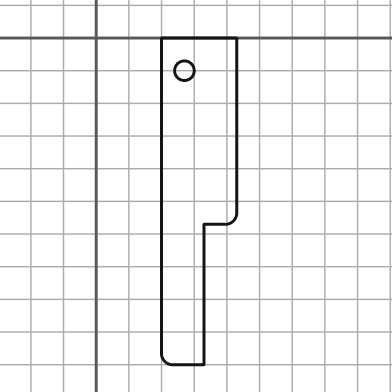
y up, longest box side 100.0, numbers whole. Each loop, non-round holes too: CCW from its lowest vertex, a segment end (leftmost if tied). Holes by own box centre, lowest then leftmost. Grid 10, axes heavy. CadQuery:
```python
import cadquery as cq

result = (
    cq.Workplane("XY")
    .moveTo(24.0, -100.0)
    .lineTo(33.0, -100.0)
    .lineTo(33.0, -57.0)
    .lineTo(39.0, -57.0)
    .threePointArc((42.0, -56.0), (43.0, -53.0))
    .lineTo(43.0, 0.0)
    .lineTo(20.0, 0.0)
    .lineTo(20.0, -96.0)
    .threePointArc((21.0, -99.0), (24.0, -100.0))
    .close()
    .moveTo(27.0, -10.0)
    .circle(3.0)
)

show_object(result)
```